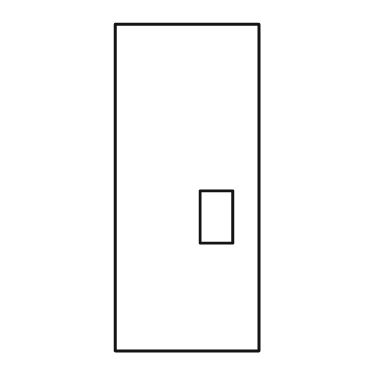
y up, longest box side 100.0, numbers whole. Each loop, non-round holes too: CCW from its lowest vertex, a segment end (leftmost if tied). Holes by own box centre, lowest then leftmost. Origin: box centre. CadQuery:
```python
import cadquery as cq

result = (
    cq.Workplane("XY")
    .moveTo(-22.0, -50.0)
    .lineTo(22.0, -50.0)
    .lineTo(22.0, 50.0)
    .lineTo(-22.0, 50.0)
    .close()
    .moveTo(4.0, -17.0)
    .lineTo(14.0, -17.0)
    .lineTo(14.0, -1.0)
    .lineTo(4.0, -1.0)
    .close()
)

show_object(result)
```